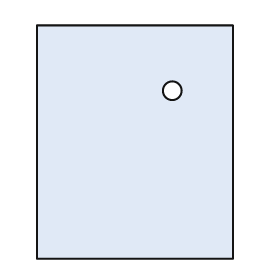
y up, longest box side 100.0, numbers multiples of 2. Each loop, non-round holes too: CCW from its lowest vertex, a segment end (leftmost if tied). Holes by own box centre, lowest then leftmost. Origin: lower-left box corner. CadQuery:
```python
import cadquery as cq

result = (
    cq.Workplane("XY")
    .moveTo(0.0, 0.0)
    .lineTo(84.0, 0.0)
    .lineTo(84.0, 100.0)
    .lineTo(0.0, 100.0)
    .close()
    .moveTo(58.0, 72.0)
    .circle(4.0)
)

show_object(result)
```